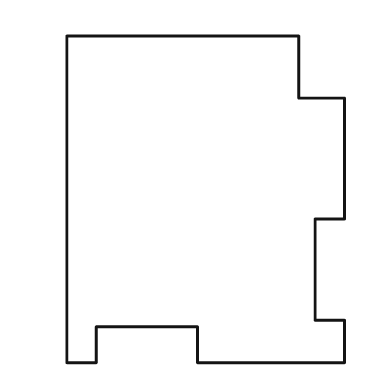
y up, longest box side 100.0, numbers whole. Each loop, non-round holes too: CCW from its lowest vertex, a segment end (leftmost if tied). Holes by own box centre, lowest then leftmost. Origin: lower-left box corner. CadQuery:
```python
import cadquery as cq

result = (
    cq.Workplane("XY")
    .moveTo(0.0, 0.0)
    .lineTo(9.0, 0.0)
    .lineTo(9.0, 11.0)
    .lineTo(40.0, 11.0)
    .lineTo(40.0, 0.0)
    .lineTo(85.0, 0.0)
    .lineTo(85.0, 13.0)
    .lineTo(76.0, 13.0)
    .lineTo(76.0, 44.0)
    .lineTo(85.0, 44.0)
    .lineTo(85.0, 81.0)
    .lineTo(71.0, 81.0)
    .lineTo(71.0, 100.0)
    .lineTo(0.0, 100.0)
    .close()
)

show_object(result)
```